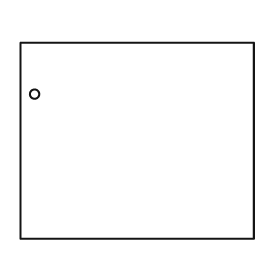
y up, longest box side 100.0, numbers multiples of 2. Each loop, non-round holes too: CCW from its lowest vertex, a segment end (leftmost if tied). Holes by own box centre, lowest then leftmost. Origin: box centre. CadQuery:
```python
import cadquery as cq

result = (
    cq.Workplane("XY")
    .moveTo(-50.0, -42.0)
    .lineTo(50.0, -42.0)
    .lineTo(50.0, 42.0)
    .lineTo(-50.0, 42.0)
    .close()
    .moveTo(-44.0, 20.0)
    .circle(2.0)
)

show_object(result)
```